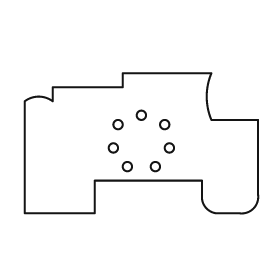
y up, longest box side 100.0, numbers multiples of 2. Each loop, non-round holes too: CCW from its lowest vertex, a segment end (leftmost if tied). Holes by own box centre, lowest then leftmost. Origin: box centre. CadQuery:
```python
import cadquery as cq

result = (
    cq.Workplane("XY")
    .moveTo(-50.0, -30.0)
    .lineTo(-20.0, -30.0)
    .lineTo(-20.0, -16.0)
    .lineTo(26.0, -16.0)
    .lineTo(26.0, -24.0)
    .threePointArc((28.0, -28.0), (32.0, -30.0))
    .lineTo(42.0, -30.0)
    .threePointArc((48.0, -28.0), (50.0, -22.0))
    .lineTo(50.0, 10.0)
    .lineTo(30.0, 10.0)
    .threePointArc((28.0, 20.0), (30.0, 30.0))
    .lineTo(-8.0, 30.0)
    .lineTo(-8.0, 24.0)
    .lineTo(-38.0, 24.0)
    .lineTo(-38.0, 18.0)
    .threePointArc((-44.0, 20.0), (-50.0, 18.0))
    .close()
    .moveTo(-6.0, -10.0)
    .circle(2.0)
    .moveTo(6.0, -10.0)
    .circle(2.0)
    .moveTo(-12.0, -2.0)
    .circle(2.0)
    .moveTo(12.0, -2.0)
    .circle(2.0)
    .moveTo(-10.0, 8.0)
    .circle(2.0)
    .moveTo(10.0, 8.0)
    .circle(2.0)
    .moveTo(0.0, 12.0)
    .circle(2.0)
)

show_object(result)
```